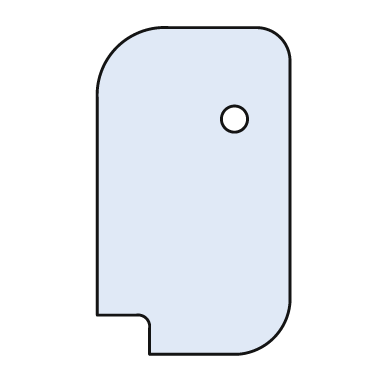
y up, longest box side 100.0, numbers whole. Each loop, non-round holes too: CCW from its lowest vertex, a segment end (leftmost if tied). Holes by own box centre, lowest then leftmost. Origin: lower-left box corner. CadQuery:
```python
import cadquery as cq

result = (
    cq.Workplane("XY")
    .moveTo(16.0, 0.0)
    .lineTo(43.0, 0.0)
    .threePointArc((54.0, 5.0), (59.0, 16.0))
    .lineTo(59.0, 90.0)
    .threePointArc((56.0, 97.0), (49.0, 100.0))
    .lineTo(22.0, 100.0)
    .threePointArc((6.0, 94.0), (0.0, 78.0))
    .lineTo(0.0, 12.0)
    .lineTo(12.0, 12.0)
    .threePointArc((15.0, 11.0), (16.0, 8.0))
    .close()
    .moveTo(42.0, 72.0)
    .circle(4.0)
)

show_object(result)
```